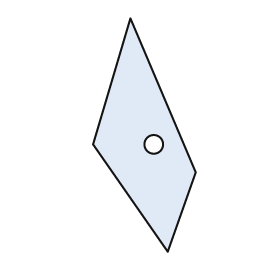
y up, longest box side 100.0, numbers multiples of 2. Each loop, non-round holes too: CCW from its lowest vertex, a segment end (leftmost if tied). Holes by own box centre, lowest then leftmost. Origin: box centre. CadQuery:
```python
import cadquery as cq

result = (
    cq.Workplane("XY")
    .moveTo(10.0, -50.0)
    .lineTo(22.0, -16.0)
    .lineTo(-6.0, 50.0)
    .lineTo(-22.0, -4.0)
    .close()
    .moveTo(4.0, -4.0)
    .circle(4.0)
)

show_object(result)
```